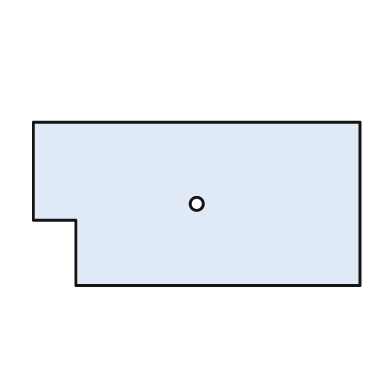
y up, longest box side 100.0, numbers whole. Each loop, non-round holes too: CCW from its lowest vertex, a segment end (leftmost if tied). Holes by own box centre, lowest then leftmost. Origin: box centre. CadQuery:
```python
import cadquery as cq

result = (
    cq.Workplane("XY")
    .moveTo(-37.0, -25.0)
    .lineTo(50.0, -25.0)
    .lineTo(50.0, 25.0)
    .lineTo(-50.0, 25.0)
    .lineTo(-50.0, -5.0)
    .lineTo(-37.0, -5.0)
    .close()
    .moveTo(0.0, 0.0)
    .circle(2.0)
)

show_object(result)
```